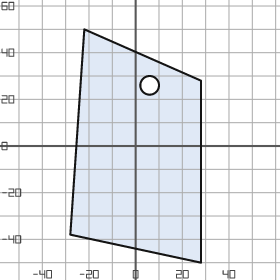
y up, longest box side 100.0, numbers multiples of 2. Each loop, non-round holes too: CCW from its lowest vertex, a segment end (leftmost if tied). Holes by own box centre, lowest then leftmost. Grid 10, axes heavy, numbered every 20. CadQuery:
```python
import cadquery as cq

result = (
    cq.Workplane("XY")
    .moveTo(28.0, -50.0)
    .lineTo(28.0, 28.0)
    .lineTo(-22.0, 50.0)
    .lineTo(-28.0, -38.0)
    .close()
    .moveTo(6.0, 26.0)
    .circle(4.0)
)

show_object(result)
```